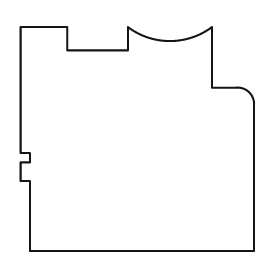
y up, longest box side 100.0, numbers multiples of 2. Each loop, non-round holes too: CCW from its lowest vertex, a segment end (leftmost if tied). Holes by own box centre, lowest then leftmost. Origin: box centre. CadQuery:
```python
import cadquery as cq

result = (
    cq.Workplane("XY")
    .moveTo(-46.0, -48.0)
    .lineTo(50.0, -48.0)
    .lineTo(50.0, 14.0)
    .threePointArc((48.0, 20.0), (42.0, 22.0))
    .lineTo(32.0, 22.0)
    .lineTo(32.0, 48.0)
    .threePointArc((14.0, 42.0), (-4.0, 48.0))
    .lineTo(-4.0, 38.0)
    .lineTo(-30.0, 38.0)
    .lineTo(-30.0, 48.0)
    .lineTo(-50.0, 48.0)
    .lineTo(-50.0, -6.0)
    .lineTo(-46.0, -6.0)
    .lineTo(-46.0, -10.0)
    .lineTo(-50.0, -10.0)
    .lineTo(-50.0, -18.0)
    .lineTo(-46.0, -18.0)
    .close()
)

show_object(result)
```